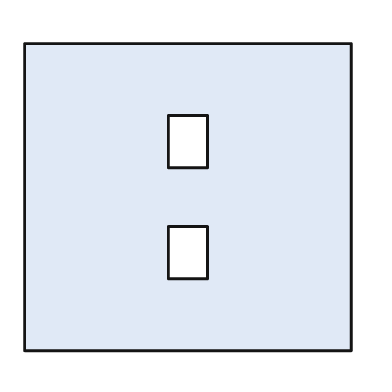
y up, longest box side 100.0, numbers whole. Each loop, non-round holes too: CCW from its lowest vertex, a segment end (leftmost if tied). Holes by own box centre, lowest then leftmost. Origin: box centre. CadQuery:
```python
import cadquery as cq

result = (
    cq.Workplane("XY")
    .moveTo(-50.0, -47.0)
    .lineTo(50.0, -47.0)
    .lineTo(50.0, 47.0)
    .lineTo(-50.0, 47.0)
    .close()
    .moveTo(-6.0, -25.0)
    .lineTo(6.0, -25.0)
    .lineTo(6.0, -9.0)
    .lineTo(-6.0, -9.0)
    .close()
    .moveTo(-6.0, 9.0)
    .lineTo(6.0, 9.0)
    .lineTo(6.0, 25.0)
    .lineTo(-6.0, 25.0)
    .close()
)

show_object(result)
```